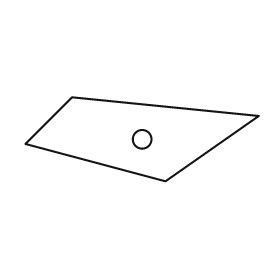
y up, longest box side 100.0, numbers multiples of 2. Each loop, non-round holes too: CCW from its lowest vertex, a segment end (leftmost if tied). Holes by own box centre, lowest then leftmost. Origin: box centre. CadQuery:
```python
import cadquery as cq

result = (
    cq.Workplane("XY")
    .moveTo(10.0, -18.0)
    .lineTo(50.0, 10.0)
    .lineTo(-30.0, 18.0)
    .lineTo(-50.0, -2.0)
    .close()
    .moveTo(0.0, 0.0)
    .circle(4.0)
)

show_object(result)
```